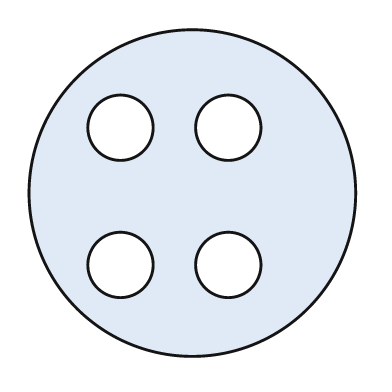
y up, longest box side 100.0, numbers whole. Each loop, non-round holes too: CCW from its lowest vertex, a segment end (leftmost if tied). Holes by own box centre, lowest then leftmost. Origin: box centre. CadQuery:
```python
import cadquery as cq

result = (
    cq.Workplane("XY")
    .moveTo(0.0, 0.0)
    .circle(50.0)
    .moveTo(-22.0, -22.0)
    .circle(10.0)
    .moveTo(11.0, -22.0)
    .circle(10.0)
    .moveTo(-22.0, 20.0)
    .circle(10.0)
    .moveTo(11.0, 20.0)
    .circle(10.0)
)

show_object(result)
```